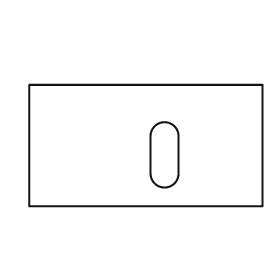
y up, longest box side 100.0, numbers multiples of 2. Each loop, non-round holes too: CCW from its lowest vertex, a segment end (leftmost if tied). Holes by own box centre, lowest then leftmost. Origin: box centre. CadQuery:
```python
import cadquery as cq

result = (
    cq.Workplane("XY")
    .moveTo(-50.0, -26.0)
    .lineTo(50.0, -26.0)
    .lineTo(50.0, 26.0)
    .lineTo(-50.0, 26.0)
    .close()
    .moveTo(2.0, -12.0)
    .threePointArc((8.0, -18.0), (14.0, -12.0))
    .lineTo(14.0, 4.0)
    .threePointArc((8.0, 10.0), (2.0, 4.0))
    .close()
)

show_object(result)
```